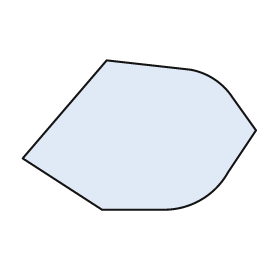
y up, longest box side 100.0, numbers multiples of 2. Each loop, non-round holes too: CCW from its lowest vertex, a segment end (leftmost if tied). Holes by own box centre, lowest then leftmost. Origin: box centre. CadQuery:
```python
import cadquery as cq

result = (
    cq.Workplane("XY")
    .moveTo(-16.0, -32.0)
    .lineTo(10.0, -32.0)
    .threePointArc((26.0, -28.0), (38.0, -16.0))
    .lineTo(50.0, 2.0)
    .lineTo(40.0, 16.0)
    .threePointArc((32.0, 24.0), (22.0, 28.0))
    .lineTo(-14.0, 32.0)
    .lineTo(-50.0, -10.0)
    .close()
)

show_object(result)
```